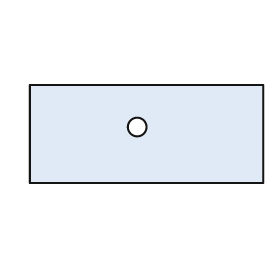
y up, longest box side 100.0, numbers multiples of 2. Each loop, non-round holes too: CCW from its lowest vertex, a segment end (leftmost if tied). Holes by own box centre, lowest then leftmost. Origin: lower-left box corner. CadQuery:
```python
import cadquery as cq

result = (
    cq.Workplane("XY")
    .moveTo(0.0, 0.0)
    .lineTo(100.0, 0.0)
    .lineTo(100.0, 42.0)
    .lineTo(0.0, 42.0)
    .close()
    .moveTo(46.0, 24.0)
    .circle(4.0)
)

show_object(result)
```